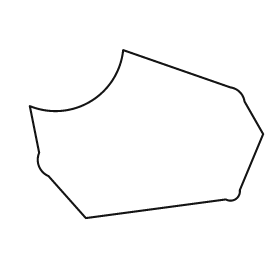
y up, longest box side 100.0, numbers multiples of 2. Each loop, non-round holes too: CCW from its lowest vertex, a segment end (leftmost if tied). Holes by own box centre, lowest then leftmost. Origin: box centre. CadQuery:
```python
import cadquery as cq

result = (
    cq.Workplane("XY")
    .moveTo(-26.0, -36.0)
    .lineTo(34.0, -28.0)
    .threePointArc((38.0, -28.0), (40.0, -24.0))
    .lineTo(50.0, 0.0)
    .lineTo(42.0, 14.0)
    .threePointArc((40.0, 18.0), (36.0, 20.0))
    .lineTo(-10.0, 36.0)
    .threePointArc((-24.0, 14.0), (-50.0, 12.0))
    .lineTo(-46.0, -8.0)
    .threePointArc((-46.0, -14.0), (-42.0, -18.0))
    .close()
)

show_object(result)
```